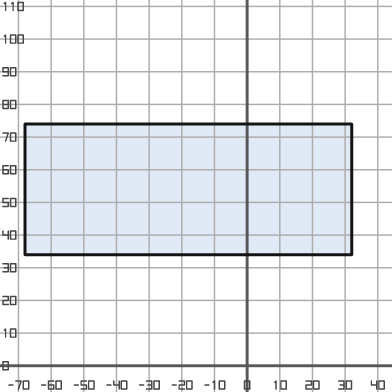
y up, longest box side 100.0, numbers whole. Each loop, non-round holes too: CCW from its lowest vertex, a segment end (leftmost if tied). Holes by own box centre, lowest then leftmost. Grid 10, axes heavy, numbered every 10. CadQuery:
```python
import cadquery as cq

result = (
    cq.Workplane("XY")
    .moveTo(-68.0, 34.0)
    .lineTo(32.0, 34.0)
    .lineTo(32.0, 74.0)
    .lineTo(-68.0, 74.0)
    .close()
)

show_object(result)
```